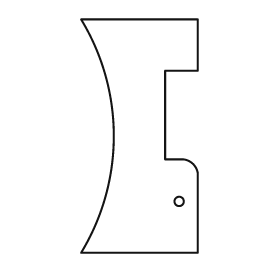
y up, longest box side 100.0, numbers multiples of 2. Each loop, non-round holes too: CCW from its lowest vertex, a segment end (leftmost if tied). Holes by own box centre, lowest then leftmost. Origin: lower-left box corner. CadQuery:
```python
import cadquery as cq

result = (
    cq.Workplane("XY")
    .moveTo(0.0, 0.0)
    .lineTo(50.0, 0.0)
    .lineTo(50.0, 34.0)
    .threePointArc((48.0, 38.0), (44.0, 40.0))
    .lineTo(36.0, 40.0)
    .lineTo(36.0, 78.0)
    .lineTo(50.0, 78.0)
    .lineTo(50.0, 100.0)
    .lineTo(0.0, 100.0)
    .threePointArc((14.0, 50.0), (0.0, 0.0))
    .close()
    .moveTo(42.0, 22.0)
    .circle(2.0)
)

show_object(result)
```